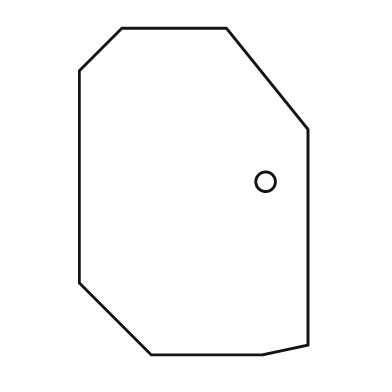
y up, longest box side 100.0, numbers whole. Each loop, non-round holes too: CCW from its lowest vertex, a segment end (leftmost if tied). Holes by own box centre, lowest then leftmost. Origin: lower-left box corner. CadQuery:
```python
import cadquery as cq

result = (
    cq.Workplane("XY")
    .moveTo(22.0, 0.0)
    .lineTo(56.0, 0.0)
    .lineTo(70.0, 3.0)
    .lineTo(70.0, 69.0)
    .lineTo(45.0, 100.0)
    .lineTo(13.0, 100.0)
    .lineTo(0.0, 87.0)
    .lineTo(0.0, 22.0)
    .close()
    .moveTo(57.0, 53.0)
    .circle(3.0)
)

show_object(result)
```